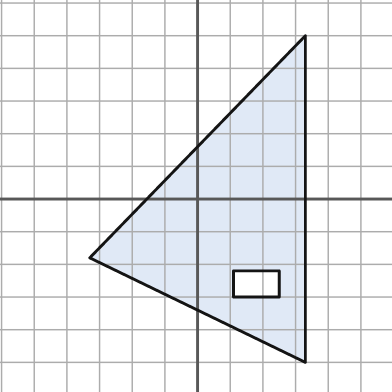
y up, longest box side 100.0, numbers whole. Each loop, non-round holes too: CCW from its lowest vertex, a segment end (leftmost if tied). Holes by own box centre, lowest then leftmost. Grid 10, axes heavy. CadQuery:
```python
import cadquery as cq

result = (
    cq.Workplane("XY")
    .moveTo(33.0, -50.0)
    .lineTo(33.0, 50.0)
    .lineTo(-33.0, -18.0)
    .close()
    .moveTo(11.0, -30.0)
    .lineTo(25.0, -30.0)
    .lineTo(25.0, -22.0)
    .lineTo(11.0, -22.0)
    .close()
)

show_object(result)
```